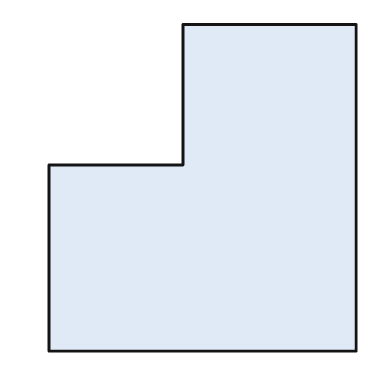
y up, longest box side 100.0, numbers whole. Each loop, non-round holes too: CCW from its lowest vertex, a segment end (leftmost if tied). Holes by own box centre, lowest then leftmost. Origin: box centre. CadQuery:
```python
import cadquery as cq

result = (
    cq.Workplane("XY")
    .moveTo(-47.0, -50.0)
    .lineTo(47.0, -50.0)
    .lineTo(47.0, 50.0)
    .lineTo(-6.0, 50.0)
    .lineTo(-6.0, 7.0)
    .lineTo(-47.0, 7.0)
    .close()
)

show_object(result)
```